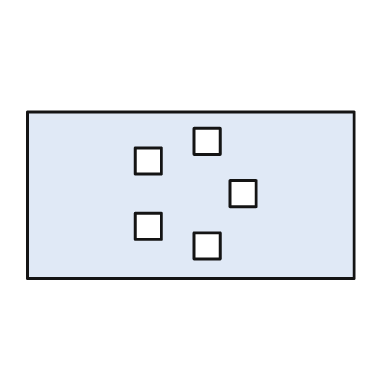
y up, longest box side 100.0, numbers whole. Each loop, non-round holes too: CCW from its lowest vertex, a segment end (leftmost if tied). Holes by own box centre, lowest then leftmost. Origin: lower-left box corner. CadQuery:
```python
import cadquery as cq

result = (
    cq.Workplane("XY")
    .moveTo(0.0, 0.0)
    .lineTo(100.0, 0.0)
    .lineTo(100.0, 51.0)
    .lineTo(0.0, 51.0)
    .close()
    .moveTo(51.0, 6.0)
    .lineTo(59.0, 6.0)
    .lineTo(59.0, 14.0)
    .lineTo(51.0, 14.0)
    .close()
    .moveTo(33.0, 12.0)
    .lineTo(41.0, 12.0)
    .lineTo(41.0, 20.0)
    .lineTo(33.0, 20.0)
    .close()
    .moveTo(62.0, 22.0)
    .lineTo(70.0, 22.0)
    .lineTo(70.0, 30.0)
    .lineTo(62.0, 30.0)
    .close()
    .moveTo(33.0, 32.0)
    .lineTo(41.0, 32.0)
    .lineTo(41.0, 40.0)
    .lineTo(33.0, 40.0)
    .close()
    .moveTo(51.0, 38.0)
    .lineTo(59.0, 38.0)
    .lineTo(59.0, 46.0)
    .lineTo(51.0, 46.0)
    .close()
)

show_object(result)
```